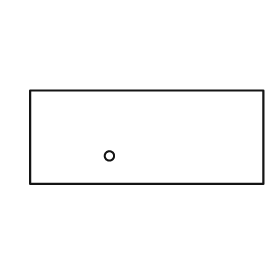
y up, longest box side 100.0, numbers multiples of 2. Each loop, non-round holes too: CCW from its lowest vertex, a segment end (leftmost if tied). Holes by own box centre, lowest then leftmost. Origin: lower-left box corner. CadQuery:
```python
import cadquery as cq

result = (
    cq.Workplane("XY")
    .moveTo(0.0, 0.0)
    .lineTo(100.0, 0.0)
    .lineTo(100.0, 40.0)
    .lineTo(0.0, 40.0)
    .close()
    .moveTo(34.0, 12.0)
    .circle(2.0)
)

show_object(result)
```